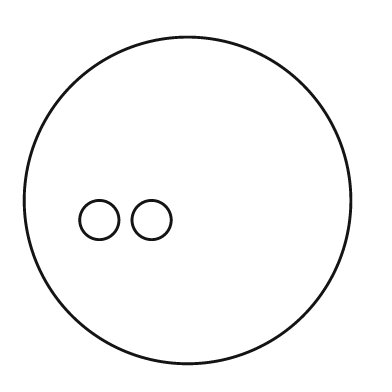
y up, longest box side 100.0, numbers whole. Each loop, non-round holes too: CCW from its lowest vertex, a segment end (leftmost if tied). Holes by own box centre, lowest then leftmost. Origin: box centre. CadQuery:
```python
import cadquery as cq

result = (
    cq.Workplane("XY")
    .moveTo(0.0, 0.0)
    .circle(50.0)
    .moveTo(-27.0, -6.0)
    .circle(6.0)
    .moveTo(-11.0, -6.0)
    .circle(6.0)
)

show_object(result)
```